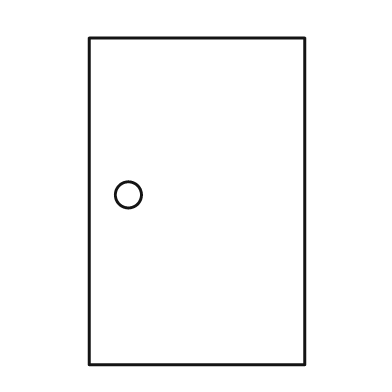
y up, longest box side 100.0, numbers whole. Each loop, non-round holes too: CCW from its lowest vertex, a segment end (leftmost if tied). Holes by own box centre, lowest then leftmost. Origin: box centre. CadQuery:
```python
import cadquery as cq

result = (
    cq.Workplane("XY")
    .moveTo(-33.0, -50.0)
    .lineTo(33.0, -50.0)
    .lineTo(33.0, 50.0)
    .lineTo(-33.0, 50.0)
    .close()
    .moveTo(-21.0, 2.0)
    .circle(4.0)
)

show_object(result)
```